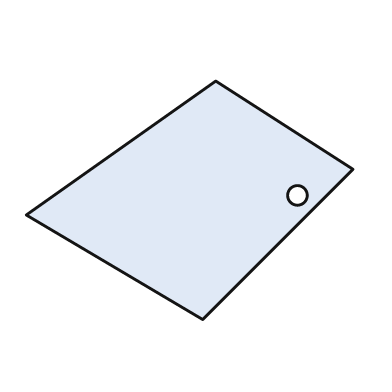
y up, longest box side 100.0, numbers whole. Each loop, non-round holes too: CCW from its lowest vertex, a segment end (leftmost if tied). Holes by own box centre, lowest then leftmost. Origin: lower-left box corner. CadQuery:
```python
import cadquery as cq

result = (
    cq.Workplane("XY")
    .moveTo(54.0, 0.0)
    .lineTo(100.0, 46.0)
    .lineTo(58.0, 73.0)
    .lineTo(0.0, 32.0)
    .close()
    .moveTo(83.0, 38.0)
    .circle(3.0)
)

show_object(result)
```